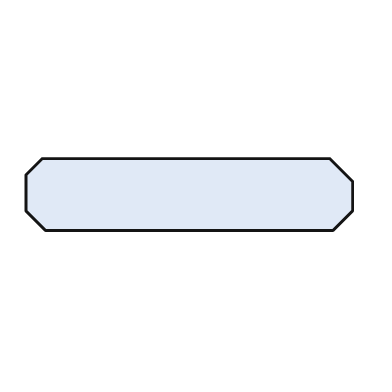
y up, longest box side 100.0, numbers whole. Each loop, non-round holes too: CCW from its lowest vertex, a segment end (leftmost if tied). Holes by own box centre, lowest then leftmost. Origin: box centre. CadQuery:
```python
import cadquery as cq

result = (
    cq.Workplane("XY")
    .moveTo(-44.0, -11.0)
    .lineTo(44.0, -11.0)
    .lineTo(50.0, -5.0)
    .lineTo(50.0, 4.0)
    .lineTo(43.0, 11.0)
    .lineTo(-45.0, 11.0)
    .lineTo(-50.0, 6.0)
    .lineTo(-50.0, -5.0)
    .close()
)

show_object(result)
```